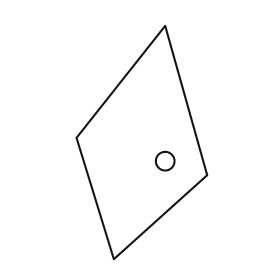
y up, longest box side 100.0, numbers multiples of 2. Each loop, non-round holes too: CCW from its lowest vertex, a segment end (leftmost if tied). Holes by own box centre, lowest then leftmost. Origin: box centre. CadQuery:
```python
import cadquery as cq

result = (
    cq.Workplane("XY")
    .moveTo(-12.0, -50.0)
    .lineTo(28.0, -14.0)
    .lineTo(10.0, 50.0)
    .lineTo(-28.0, 2.0)
    .close()
    .moveTo(10.0, -8.0)
    .circle(4.0)
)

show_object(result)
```